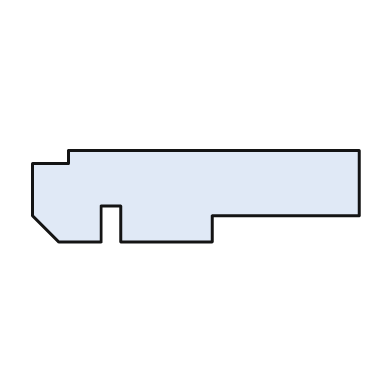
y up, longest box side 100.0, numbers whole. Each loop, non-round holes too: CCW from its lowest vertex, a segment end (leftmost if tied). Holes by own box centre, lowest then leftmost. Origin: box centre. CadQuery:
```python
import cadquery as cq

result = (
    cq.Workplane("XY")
    .moveTo(-42.0, -14.0)
    .lineTo(-29.0, -14.0)
    .lineTo(-29.0, -3.0)
    .lineTo(-23.0, -3.0)
    .lineTo(-23.0, -14.0)
    .lineTo(5.0, -14.0)
    .lineTo(5.0, -6.0)
    .lineTo(50.0, -6.0)
    .lineTo(50.0, 14.0)
    .lineTo(-39.0, 14.0)
    .lineTo(-39.0, 10.0)
    .lineTo(-50.0, 10.0)
    .lineTo(-50.0, -6.0)
    .close()
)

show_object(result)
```